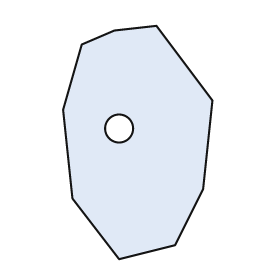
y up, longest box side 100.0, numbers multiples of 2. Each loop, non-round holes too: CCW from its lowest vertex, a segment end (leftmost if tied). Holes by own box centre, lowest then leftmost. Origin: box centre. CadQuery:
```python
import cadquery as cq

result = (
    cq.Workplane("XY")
    .moveTo(-8.0, -50.0)
    .lineTo(16.0, -44.0)
    .lineTo(28.0, -20.0)
    .lineTo(32.0, 18.0)
    .lineTo(8.0, 50.0)
    .lineTo(-10.0, 48.0)
    .lineTo(-24.0, 42.0)
    .lineTo(-32.0, 14.0)
    .lineTo(-28.0, -24.0)
    .close()
    .moveTo(-8.0, 6.0)
    .circle(6.0)
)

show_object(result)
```